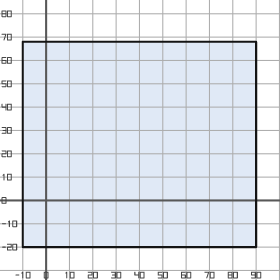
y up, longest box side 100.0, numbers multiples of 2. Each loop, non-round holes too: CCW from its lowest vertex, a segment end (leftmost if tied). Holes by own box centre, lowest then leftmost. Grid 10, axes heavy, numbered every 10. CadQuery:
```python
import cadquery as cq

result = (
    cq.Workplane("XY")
    .moveTo(-10.0, -20.0)
    .lineTo(90.0, -20.0)
    .lineTo(90.0, 68.0)
    .lineTo(-10.0, 68.0)
    .close()
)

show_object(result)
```